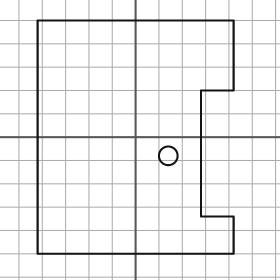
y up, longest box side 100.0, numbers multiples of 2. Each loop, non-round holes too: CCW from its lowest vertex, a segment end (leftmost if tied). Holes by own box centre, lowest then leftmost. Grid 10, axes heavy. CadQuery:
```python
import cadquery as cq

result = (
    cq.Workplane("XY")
    .moveTo(-42.0, -50.0)
    .lineTo(42.0, -50.0)
    .lineTo(42.0, -34.0)
    .lineTo(28.0, -34.0)
    .lineTo(28.0, 20.0)
    .lineTo(42.0, 20.0)
    .lineTo(42.0, 50.0)
    .lineTo(-42.0, 50.0)
    .close()
    .moveTo(14.0, -8.0)
    .circle(4.0)
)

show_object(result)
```